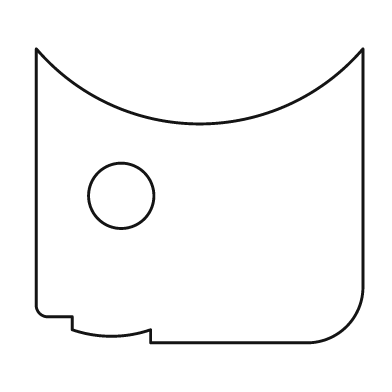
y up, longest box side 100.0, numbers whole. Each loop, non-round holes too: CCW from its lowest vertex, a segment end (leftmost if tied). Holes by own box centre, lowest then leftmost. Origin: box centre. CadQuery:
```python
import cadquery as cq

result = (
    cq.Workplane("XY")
    .moveTo(-15.0, -45.0)
    .lineTo(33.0, -45.0)
    .threePointArc((45.0, -40.0), (50.0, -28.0))
    .lineTo(50.0, 45.0)
    .threePointArc((0.0, 22.0), (-50.0, 45.0))
    .lineTo(-50.0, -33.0)
    .threePointArc((-49.0, -36.0), (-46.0, -37.0))
    .lineTo(-39.0, -37.0)
    .lineTo(-39.0, -41.0)
    .threePointArc((-27.0, -43.0), (-15.0, -41.0))
    .close()
    .moveTo(-24.0, 0.0)
    .circle(10.0)
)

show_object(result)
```